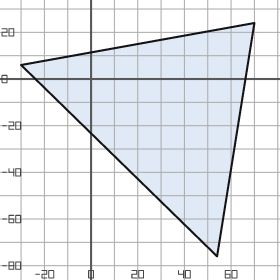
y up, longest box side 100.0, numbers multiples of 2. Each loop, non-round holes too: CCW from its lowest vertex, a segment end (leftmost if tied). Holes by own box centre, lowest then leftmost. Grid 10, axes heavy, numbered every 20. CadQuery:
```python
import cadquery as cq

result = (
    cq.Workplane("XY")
    .moveTo(54.0, -76.0)
    .lineTo(70.0, 24.0)
    .lineTo(-30.0, 6.0)
    .close()
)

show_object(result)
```